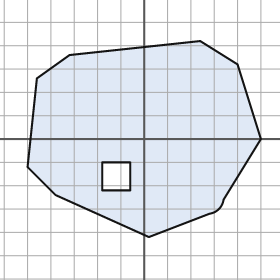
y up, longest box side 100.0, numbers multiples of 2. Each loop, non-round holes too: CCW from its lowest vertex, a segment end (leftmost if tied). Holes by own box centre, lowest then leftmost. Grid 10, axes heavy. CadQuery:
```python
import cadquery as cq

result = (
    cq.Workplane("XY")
    .moveTo(2.0, -42.0)
    .lineTo(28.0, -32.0)
    .threePointArc((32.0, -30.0), (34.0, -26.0))
    .lineTo(50.0, 0.0)
    .lineTo(40.0, 32.0)
    .lineTo(24.0, 42.0)
    .lineTo(-32.0, 36.0)
    .lineTo(-46.0, 26.0)
    .lineTo(-50.0, -12.0)
    .lineTo(-38.0, -24.0)
    .close()
    .moveTo(-18.0, -22.0)
    .lineTo(-6.0, -22.0)
    .lineTo(-6.0, -10.0)
    .lineTo(-18.0, -10.0)
    .close()
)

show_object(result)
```